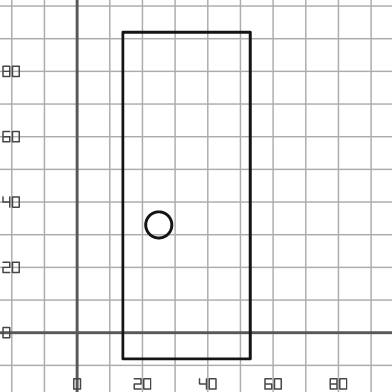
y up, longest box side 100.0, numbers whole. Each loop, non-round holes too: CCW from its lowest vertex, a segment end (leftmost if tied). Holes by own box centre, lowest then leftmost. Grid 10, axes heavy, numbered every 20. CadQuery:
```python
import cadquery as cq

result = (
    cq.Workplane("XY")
    .moveTo(14.0, -8.0)
    .lineTo(53.0, -8.0)
    .lineTo(53.0, 92.0)
    .lineTo(14.0, 92.0)
    .close()
    .moveTo(25.0, 33.0)
    .circle(4.0)
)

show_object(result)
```